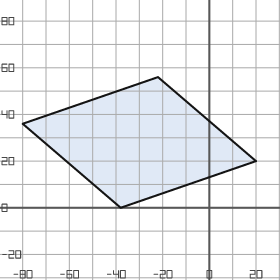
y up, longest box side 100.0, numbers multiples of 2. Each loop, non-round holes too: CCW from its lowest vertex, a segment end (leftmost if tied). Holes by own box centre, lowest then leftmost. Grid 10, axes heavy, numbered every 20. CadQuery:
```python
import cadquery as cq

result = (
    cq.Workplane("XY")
    .moveTo(-38.0, 0.0)
    .lineTo(20.0, 20.0)
    .lineTo(-22.0, 56.0)
    .lineTo(-80.0, 36.0)
    .close()
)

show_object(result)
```